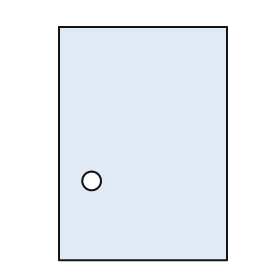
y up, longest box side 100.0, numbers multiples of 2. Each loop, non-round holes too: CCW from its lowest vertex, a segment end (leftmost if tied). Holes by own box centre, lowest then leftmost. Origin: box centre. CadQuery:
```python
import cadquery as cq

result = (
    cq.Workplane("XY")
    .moveTo(-36.0, -50.0)
    .lineTo(36.0, -50.0)
    .lineTo(36.0, 50.0)
    .lineTo(-36.0, 50.0)
    .close()
    .moveTo(-22.0, -16.0)
    .circle(4.0)
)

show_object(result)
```